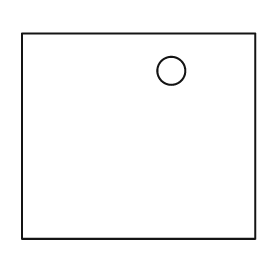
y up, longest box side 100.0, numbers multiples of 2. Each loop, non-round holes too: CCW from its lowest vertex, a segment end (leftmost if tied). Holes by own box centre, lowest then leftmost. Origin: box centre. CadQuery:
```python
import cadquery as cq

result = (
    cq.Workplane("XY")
    .moveTo(-50.0, -44.0)
    .lineTo(50.0, -44.0)
    .lineTo(50.0, 44.0)
    .lineTo(-50.0, 44.0)
    .close()
    .moveTo(14.0, 28.0)
    .circle(6.0)
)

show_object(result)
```